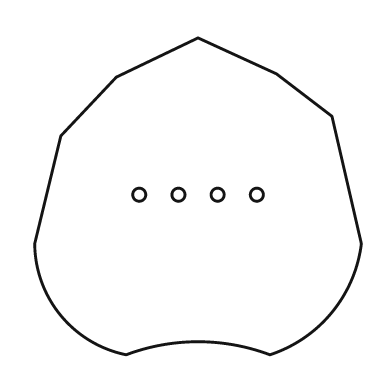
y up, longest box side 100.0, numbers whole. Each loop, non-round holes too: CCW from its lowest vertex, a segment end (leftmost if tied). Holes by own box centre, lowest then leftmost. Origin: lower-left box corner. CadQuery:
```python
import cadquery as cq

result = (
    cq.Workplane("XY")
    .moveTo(28.0, 0.0)
    .threePointArc((50.0, 4.0), (72.0, 0.0))
    .threePointArc((91.0, 13.0), (100.0, 34.0))
    .lineTo(91.0, 73.0)
    .lineTo(74.0, 86.0)
    .lineTo(50.0, 97.0)
    .lineTo(25.0, 85.0)
    .lineTo(8.0, 67.0)
    .lineTo(0.0, 34.0)
    .threePointArc((8.0, 12.0), (28.0, 0.0))
    .close()
    .moveTo(32.0, 49.0)
    .circle(2.0)
    .moveTo(44.0, 49.0)
    .circle(2.0)
    .moveTo(56.0, 49.0)
    .circle(2.0)
    .moveTo(68.0, 49.0)
    .circle(2.0)
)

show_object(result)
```